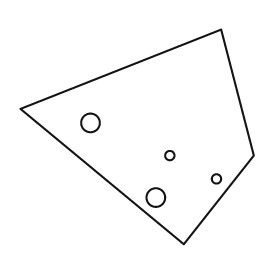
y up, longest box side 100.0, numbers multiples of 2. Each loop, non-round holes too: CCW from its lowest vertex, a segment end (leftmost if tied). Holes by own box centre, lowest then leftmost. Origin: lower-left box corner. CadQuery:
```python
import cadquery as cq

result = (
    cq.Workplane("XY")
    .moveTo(70.0, 0.0)
    .lineTo(100.0, 38.0)
    .lineTo(86.0, 92.0)
    .lineTo(0.0, 58.0)
    .close()
    .moveTo(58.0, 20.0)
    .circle(4.0)
    .moveTo(84.0, 28.0)
    .circle(2.0)
    .moveTo(64.0, 38.0)
    .circle(2.0)
    .moveTo(30.0, 52.0)
    .circle(4.0)
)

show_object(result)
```